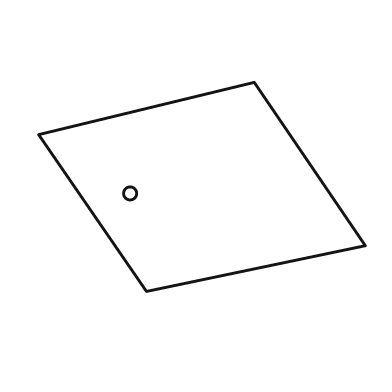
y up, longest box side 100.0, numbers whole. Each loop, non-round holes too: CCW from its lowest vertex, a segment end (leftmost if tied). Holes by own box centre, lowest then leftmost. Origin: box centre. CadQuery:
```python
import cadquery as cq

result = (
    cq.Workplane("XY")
    .moveTo(-17.0, -32.0)
    .lineTo(50.0, -18.0)
    .lineTo(16.0, 32.0)
    .lineTo(-50.0, 16.0)
    .close()
    .moveTo(-22.0, -2.0)
    .circle(2.0)
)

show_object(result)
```